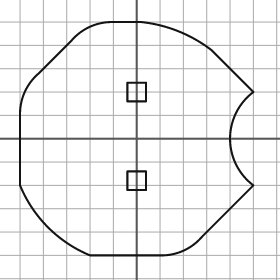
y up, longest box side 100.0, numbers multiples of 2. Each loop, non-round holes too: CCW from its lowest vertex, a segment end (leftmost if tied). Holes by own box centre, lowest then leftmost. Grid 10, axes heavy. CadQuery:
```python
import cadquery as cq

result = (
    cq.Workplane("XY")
    .moveTo(-20.0, -50.0)
    .lineTo(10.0, -50.0)
    .threePointArc((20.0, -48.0), (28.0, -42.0))
    .lineTo(50.0, -20.0)
    .threePointArc((40.0, 0.0), (50.0, 20.0))
    .lineTo(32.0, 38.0)
    .threePointArc((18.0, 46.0), (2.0, 50.0))
    .lineTo(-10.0, 50.0)
    .threePointArc((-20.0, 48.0), (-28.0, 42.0))
    .lineTo(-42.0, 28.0)
    .threePointArc((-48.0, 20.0), (-50.0, 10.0))
    .lineTo(-50.0, -20.0)
    .threePointArc((-38.0, -38.0), (-20.0, -50.0))
    .close()
    .moveTo(-4.0, -22.0)
    .lineTo(4.0, -22.0)
    .lineTo(4.0, -14.0)
    .lineTo(-4.0, -14.0)
    .close()
    .moveTo(-4.0, 16.0)
    .lineTo(4.0, 16.0)
    .lineTo(4.0, 24.0)
    .lineTo(-4.0, 24.0)
    .close()
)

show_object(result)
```